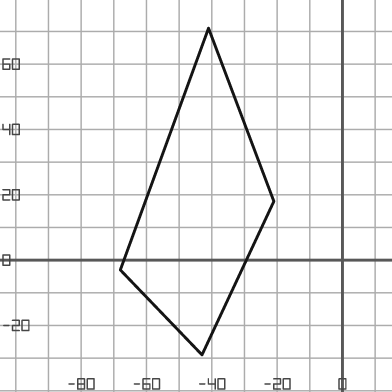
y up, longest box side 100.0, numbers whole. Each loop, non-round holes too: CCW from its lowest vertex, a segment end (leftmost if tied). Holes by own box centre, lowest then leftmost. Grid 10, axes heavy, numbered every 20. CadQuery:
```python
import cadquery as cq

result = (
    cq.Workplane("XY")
    .moveTo(-43.0, -29.0)
    .lineTo(-21.0, 18.0)
    .lineTo(-41.0, 71.0)
    .lineTo(-68.0, -3.0)
    .close()
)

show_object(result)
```